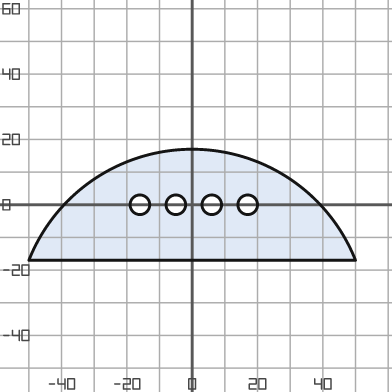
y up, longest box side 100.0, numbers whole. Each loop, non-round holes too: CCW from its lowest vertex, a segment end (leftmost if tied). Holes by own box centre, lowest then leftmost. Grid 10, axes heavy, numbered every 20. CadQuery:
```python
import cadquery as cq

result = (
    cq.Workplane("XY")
    .moveTo(-50.0, -17.0)
    .lineTo(50.0, -17.0)
    .threePointArc((0.0, 17.0), (-50.0, -17.0))
    .close()
    .moveTo(-16.0, 0.0)
    .circle(3.0)
    .moveTo(-5.0, 0.0)
    .circle(3.0)
    .moveTo(6.0, 0.0)
    .circle(3.0)
    .moveTo(17.0, 0.0)
    .circle(3.0)
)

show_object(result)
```